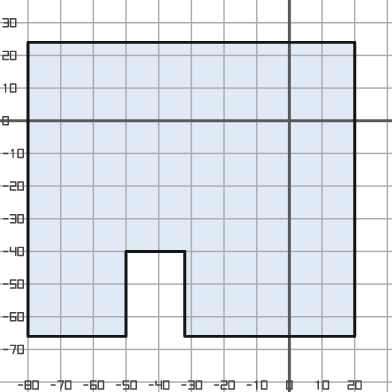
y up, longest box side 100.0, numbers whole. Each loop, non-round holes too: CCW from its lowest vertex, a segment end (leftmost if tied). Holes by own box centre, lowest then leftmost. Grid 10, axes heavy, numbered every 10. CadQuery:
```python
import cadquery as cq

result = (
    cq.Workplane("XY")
    .moveTo(-80.0, -66.0)
    .lineTo(-50.0, -66.0)
    .lineTo(-50.0, -40.0)
    .lineTo(-32.0, -40.0)
    .lineTo(-32.0, -66.0)
    .lineTo(20.0, -66.0)
    .lineTo(20.0, 24.0)
    .lineTo(-80.0, 24.0)
    .close()
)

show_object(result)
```